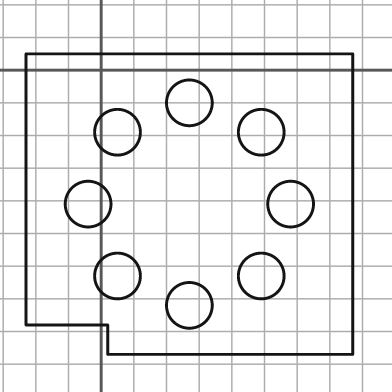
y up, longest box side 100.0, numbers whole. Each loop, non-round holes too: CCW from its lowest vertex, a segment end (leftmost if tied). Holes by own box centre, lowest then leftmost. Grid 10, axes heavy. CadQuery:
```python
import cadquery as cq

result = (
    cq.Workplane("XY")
    .moveTo(2.0, -87.0)
    .lineTo(77.0, -87.0)
    .lineTo(77.0, 5.0)
    .lineTo(-23.0, 5.0)
    .lineTo(-23.0, -78.0)
    .lineTo(2.0, -78.0)
    .close()
    .moveTo(27.0, -72.0)
    .circle(7.0)
    .moveTo(5.0, -63.0)
    .circle(7.0)
    .moveTo(49.0, -63.0)
    .circle(7.0)
    .moveTo(-4.0, -41.0)
    .circle(7.0)
    .moveTo(58.0, -41.0)
    .circle(7.0)
    .moveTo(5.0, -19.0)
    .circle(7.0)
    .moveTo(49.0, -19.0)
    .circle(7.0)
    .moveTo(27.0, -10.0)
    .circle(7.0)
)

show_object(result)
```